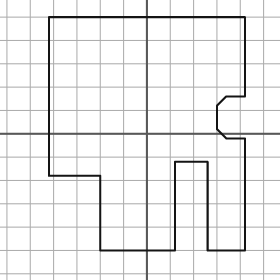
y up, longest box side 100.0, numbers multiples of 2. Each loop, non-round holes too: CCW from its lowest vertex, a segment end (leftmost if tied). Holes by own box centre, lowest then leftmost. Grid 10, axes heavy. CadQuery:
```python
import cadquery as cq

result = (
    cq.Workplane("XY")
    .moveTo(-20.0, -50.0)
    .lineTo(12.0, -50.0)
    .lineTo(12.0, -12.0)
    .lineTo(26.0, -12.0)
    .lineTo(26.0, -50.0)
    .lineTo(42.0, -50.0)
    .lineTo(42.0, -2.0)
    .lineTo(34.0, -2.0)
    .lineTo(30.0, 2.0)
    .lineTo(30.0, 12.0)
    .lineTo(34.0, 16.0)
    .lineTo(42.0, 16.0)
    .lineTo(42.0, 50.0)
    .lineTo(-42.0, 50.0)
    .lineTo(-42.0, -18.0)
    .lineTo(-20.0, -18.0)
    .close()
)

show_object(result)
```